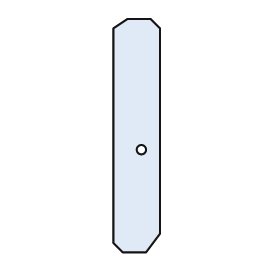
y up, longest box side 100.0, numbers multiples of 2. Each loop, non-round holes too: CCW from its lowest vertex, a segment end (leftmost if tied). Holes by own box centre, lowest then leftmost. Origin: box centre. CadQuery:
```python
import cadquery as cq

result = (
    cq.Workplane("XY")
    .moveTo(-6.0, -50.0)
    .lineTo(4.0, -50.0)
    .lineTo(10.0, -42.0)
    .lineTo(10.0, 46.0)
    .lineTo(6.0, 50.0)
    .lineTo(-4.0, 50.0)
    .lineTo(-10.0, 46.0)
    .lineTo(-10.0, -46.0)
    .close()
    .moveTo(2.0, -6.0)
    .circle(2.0)
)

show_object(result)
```